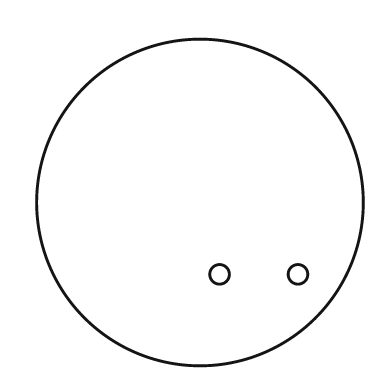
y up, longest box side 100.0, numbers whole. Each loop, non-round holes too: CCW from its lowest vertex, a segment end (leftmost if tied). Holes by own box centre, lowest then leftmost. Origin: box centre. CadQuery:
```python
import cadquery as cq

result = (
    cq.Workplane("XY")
    .moveTo(0.0, 0.0)
    .circle(50.0)
    .moveTo(6.0, -22.0)
    .circle(3.0)
    .moveTo(30.0, -22.0)
    .circle(3.0)
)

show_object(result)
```